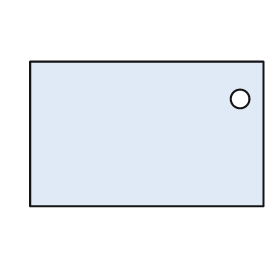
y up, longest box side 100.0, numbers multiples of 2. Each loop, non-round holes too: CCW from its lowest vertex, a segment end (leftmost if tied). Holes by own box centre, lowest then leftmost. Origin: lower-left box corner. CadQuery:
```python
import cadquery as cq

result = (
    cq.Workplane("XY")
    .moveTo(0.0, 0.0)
    .lineTo(100.0, 0.0)
    .lineTo(100.0, 62.0)
    .lineTo(0.0, 62.0)
    .close()
    .moveTo(90.0, 46.0)
    .circle(4.0)
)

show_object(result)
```